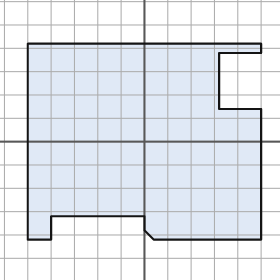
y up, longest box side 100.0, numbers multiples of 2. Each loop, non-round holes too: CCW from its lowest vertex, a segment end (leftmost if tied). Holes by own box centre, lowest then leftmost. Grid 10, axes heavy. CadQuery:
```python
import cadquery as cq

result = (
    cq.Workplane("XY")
    .moveTo(-50.0, -42.0)
    .lineTo(-40.0, -42.0)
    .lineTo(-40.0, -32.0)
    .lineTo(0.0, -32.0)
    .lineTo(0.0, -38.0)
    .lineTo(4.0, -42.0)
    .lineTo(50.0, -42.0)
    .lineTo(50.0, 14.0)
    .lineTo(32.0, 14.0)
    .lineTo(32.0, 38.0)
    .lineTo(50.0, 38.0)
    .lineTo(50.0, 42.0)
    .lineTo(-50.0, 42.0)
    .close()
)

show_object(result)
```